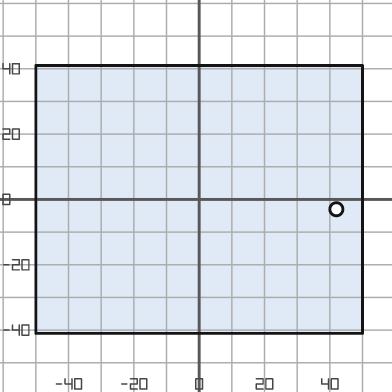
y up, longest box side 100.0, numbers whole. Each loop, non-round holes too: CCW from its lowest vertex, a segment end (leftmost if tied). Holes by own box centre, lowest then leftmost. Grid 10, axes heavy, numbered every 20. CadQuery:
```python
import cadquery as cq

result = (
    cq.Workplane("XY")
    .moveTo(-50.0, -41.0)
    .lineTo(50.0, -41.0)
    .lineTo(50.0, 41.0)
    .lineTo(-50.0, 41.0)
    .close()
    .moveTo(42.0, -3.0)
    .circle(2.0)
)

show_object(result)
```